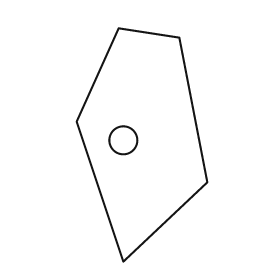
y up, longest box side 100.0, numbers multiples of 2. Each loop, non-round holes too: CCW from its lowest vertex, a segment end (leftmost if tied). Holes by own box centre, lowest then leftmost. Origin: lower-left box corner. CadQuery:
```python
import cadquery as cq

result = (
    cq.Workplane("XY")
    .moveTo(20.0, 0.0)
    .lineTo(56.0, 34.0)
    .lineTo(44.0, 96.0)
    .lineTo(18.0, 100.0)
    .lineTo(0.0, 60.0)
    .close()
    .moveTo(20.0, 52.0)
    .circle(6.0)
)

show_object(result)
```